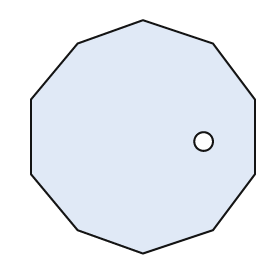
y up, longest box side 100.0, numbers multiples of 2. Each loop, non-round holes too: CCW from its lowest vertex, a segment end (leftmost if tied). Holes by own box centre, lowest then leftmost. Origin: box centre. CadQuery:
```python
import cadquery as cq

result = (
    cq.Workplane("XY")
    .moveTo(0.0, -50.0)
    .lineTo(30.0, -40.0)
    .lineTo(48.0, -16.0)
    .lineTo(48.0, 16.0)
    .lineTo(30.0, 40.0)
    .lineTo(0.0, 50.0)
    .lineTo(-28.0, 40.0)
    .lineTo(-48.0, 16.0)
    .lineTo(-48.0, -16.0)
    .lineTo(-28.0, -40.0)
    .close()
    .moveTo(26.0, -2.0)
    .circle(4.0)
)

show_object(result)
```